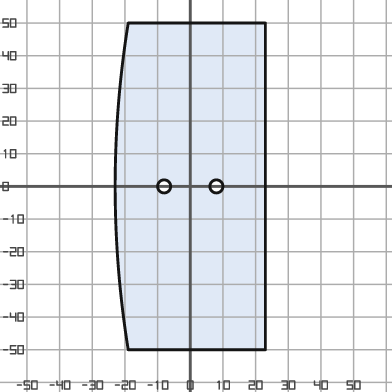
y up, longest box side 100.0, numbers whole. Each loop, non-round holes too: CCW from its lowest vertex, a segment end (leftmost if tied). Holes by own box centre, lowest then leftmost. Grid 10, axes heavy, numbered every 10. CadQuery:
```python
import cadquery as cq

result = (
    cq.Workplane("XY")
    .moveTo(-19.0, -50.0)
    .lineTo(23.0, -50.0)
    .lineTo(23.0, 50.0)
    .lineTo(-19.0, 50.0)
    .threePointArc((-23.0, 0.0), (-19.0, -50.0))
    .close()
    .moveTo(-8.0, 0.0)
    .circle(2.0)
    .moveTo(8.0, 0.0)
    .circle(2.0)
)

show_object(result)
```